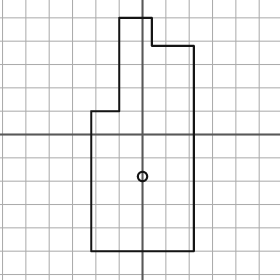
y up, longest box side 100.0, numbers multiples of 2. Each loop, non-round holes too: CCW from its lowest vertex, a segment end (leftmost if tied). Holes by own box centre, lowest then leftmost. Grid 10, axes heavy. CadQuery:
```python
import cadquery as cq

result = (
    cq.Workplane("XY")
    .moveTo(-22.0, -50.0)
    .lineTo(22.0, -50.0)
    .lineTo(22.0, 38.0)
    .lineTo(4.0, 38.0)
    .lineTo(4.0, 50.0)
    .lineTo(-10.0, 50.0)
    .lineTo(-10.0, 10.0)
    .lineTo(-22.0, 10.0)
    .close()
    .moveTo(0.0, -18.0)
    .circle(2.0)
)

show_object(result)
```